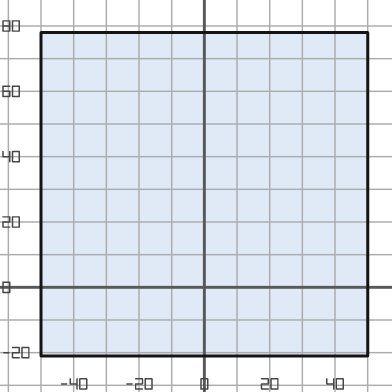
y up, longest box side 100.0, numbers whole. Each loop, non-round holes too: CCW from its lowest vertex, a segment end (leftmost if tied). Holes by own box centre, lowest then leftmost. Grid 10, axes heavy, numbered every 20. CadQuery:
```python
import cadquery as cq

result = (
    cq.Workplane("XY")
    .moveTo(-50.0, -21.0)
    .lineTo(50.0, -21.0)
    .lineTo(50.0, 78.0)
    .lineTo(-50.0, 78.0)
    .close()
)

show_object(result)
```